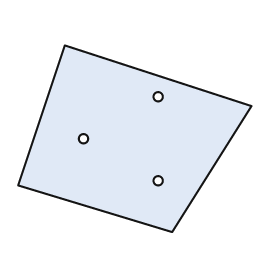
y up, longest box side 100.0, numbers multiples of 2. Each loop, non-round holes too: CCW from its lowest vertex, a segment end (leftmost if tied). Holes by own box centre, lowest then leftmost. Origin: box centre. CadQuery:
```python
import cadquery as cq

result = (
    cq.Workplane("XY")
    .moveTo(16.0, -40.0)
    .lineTo(50.0, 14.0)
    .lineTo(-30.0, 40.0)
    .lineTo(-50.0, -20.0)
    .close()
    .moveTo(10.0, -18.0)
    .circle(2.0)
    .moveTo(-22.0, 0.0)
    .circle(2.0)
    .moveTo(10.0, 18.0)
    .circle(2.0)
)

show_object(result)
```